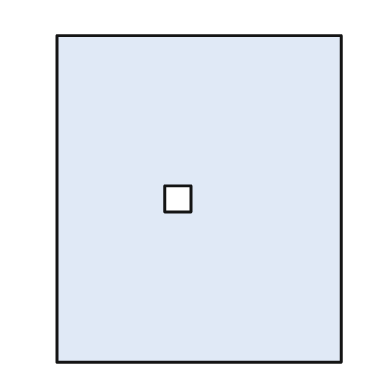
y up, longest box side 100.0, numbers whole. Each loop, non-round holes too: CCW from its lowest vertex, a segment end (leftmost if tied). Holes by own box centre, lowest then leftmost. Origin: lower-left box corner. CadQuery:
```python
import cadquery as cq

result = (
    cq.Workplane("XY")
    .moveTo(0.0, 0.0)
    .lineTo(87.0, 0.0)
    .lineTo(87.0, 100.0)
    .lineTo(0.0, 100.0)
    .close()
    .moveTo(33.0, 46.0)
    .lineTo(41.0, 46.0)
    .lineTo(41.0, 54.0)
    .lineTo(33.0, 54.0)
    .close()
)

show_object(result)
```